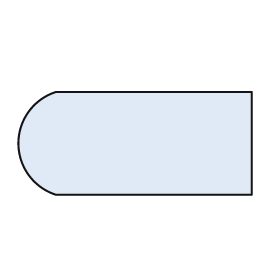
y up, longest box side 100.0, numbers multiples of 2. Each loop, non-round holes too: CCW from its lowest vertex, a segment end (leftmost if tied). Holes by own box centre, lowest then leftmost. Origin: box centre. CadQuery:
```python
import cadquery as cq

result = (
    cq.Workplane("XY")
    .moveTo(-34.0, -22.0)
    .lineTo(50.0, -22.0)
    .lineTo(50.0, 22.0)
    .lineTo(-34.0, 22.0)
    .threePointArc((-50.0, 0.0), (-34.0, -22.0))
    .close()
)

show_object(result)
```